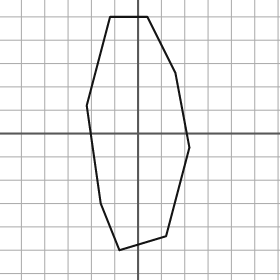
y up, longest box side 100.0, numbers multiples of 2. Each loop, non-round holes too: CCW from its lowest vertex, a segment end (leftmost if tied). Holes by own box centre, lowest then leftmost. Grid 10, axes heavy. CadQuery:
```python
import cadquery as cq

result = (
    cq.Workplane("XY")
    .moveTo(-8.0, -50.0)
    .lineTo(12.0, -44.0)
    .lineTo(22.0, -6.0)
    .lineTo(16.0, 26.0)
    .lineTo(4.0, 50.0)
    .lineTo(-12.0, 50.0)
    .lineTo(-22.0, 12.0)
    .lineTo(-16.0, -30.0)
    .close()
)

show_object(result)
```